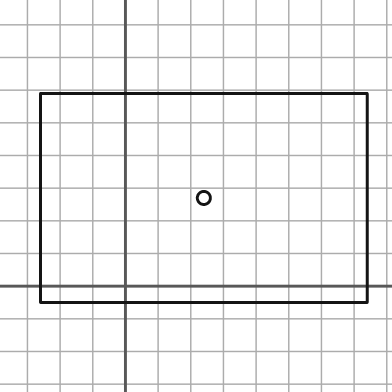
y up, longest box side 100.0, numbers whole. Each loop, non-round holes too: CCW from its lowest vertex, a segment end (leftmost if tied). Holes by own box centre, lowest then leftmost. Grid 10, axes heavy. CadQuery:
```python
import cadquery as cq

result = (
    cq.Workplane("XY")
    .moveTo(-26.0, -5.0)
    .lineTo(74.0, -5.0)
    .lineTo(74.0, 59.0)
    .lineTo(-26.0, 59.0)
    .close()
    .moveTo(24.0, 27.0)
    .circle(2.0)
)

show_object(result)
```